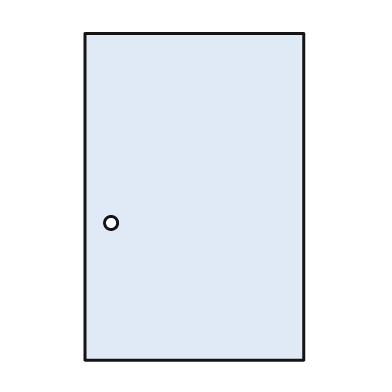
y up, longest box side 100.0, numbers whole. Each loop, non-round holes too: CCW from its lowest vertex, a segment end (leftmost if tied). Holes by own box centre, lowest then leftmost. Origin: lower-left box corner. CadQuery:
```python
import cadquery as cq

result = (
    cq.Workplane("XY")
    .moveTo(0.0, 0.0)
    .lineTo(67.0, 0.0)
    .lineTo(67.0, 100.0)
    .lineTo(0.0, 100.0)
    .close()
    .moveTo(8.0, 42.0)
    .circle(2.0)
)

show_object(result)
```